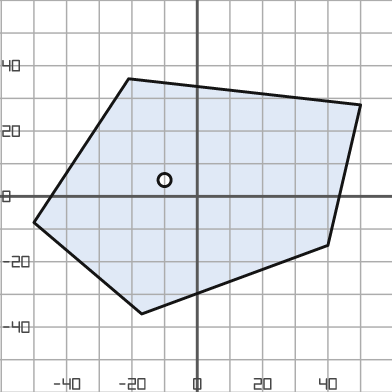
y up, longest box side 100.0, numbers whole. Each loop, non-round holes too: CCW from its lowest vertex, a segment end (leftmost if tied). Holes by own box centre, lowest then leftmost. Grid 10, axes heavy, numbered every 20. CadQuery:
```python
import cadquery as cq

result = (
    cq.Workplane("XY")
    .moveTo(-17.0, -36.0)
    .lineTo(40.0, -15.0)
    .lineTo(50.0, 28.0)
    .lineTo(-21.0, 36.0)
    .lineTo(-50.0, -8.0)
    .close()
    .moveTo(-10.0, 5.0)
    .circle(2.0)
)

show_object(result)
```